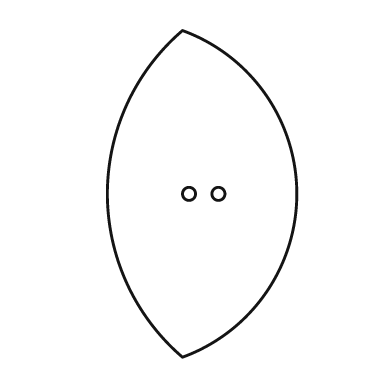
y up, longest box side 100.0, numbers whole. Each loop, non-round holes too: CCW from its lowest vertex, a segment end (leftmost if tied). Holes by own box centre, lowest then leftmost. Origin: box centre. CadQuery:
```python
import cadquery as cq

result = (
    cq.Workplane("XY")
    .moveTo(-6.0, -50.0)
    .threePointArc((29.0, 0.0), (-6.0, 50.0))
    .threePointArc((-29.0, 0.0), (-6.0, -50.0))
    .close()
    .moveTo(-4.0, 0.0)
    .circle(2.0)
    .moveTo(5.0, 0.0)
    .circle(2.0)
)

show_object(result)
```